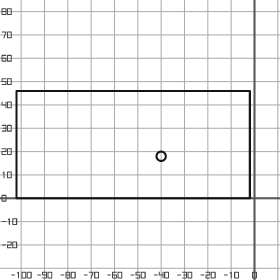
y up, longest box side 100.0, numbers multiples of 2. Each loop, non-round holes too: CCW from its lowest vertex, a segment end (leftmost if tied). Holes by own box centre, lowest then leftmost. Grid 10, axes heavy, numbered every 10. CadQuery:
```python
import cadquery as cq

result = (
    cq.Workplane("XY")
    .moveTo(-102.0, 0.0)
    .lineTo(-2.0, 0.0)
    .lineTo(-2.0, 46.0)
    .lineTo(-102.0, 46.0)
    .close()
    .moveTo(-40.0, 18.0)
    .circle(2.0)
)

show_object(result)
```